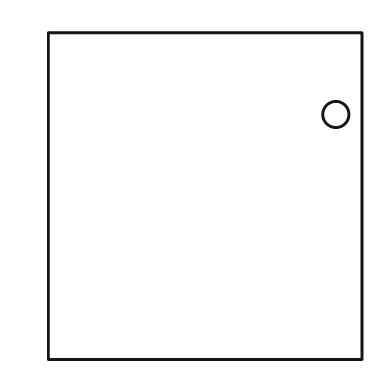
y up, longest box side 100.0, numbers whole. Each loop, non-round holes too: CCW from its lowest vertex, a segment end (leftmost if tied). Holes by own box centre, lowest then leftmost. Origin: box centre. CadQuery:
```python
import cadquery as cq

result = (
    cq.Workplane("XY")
    .moveTo(-48.0, -50.0)
    .lineTo(48.0, -50.0)
    .lineTo(48.0, 50.0)
    .lineTo(-48.0, 50.0)
    .close()
    .moveTo(40.0, 25.0)
    .circle(4.0)
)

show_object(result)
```